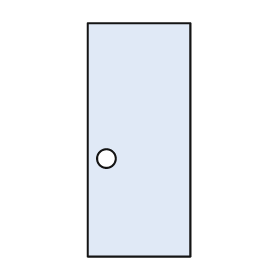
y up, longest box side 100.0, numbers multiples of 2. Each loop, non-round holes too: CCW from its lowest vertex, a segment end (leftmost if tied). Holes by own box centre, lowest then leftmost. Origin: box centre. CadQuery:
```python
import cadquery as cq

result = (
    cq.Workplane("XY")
    .moveTo(-22.0, -50.0)
    .lineTo(22.0, -50.0)
    .lineTo(22.0, 50.0)
    .lineTo(-22.0, 50.0)
    .close()
    .moveTo(-14.0, -8.0)
    .circle(4.0)
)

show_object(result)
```